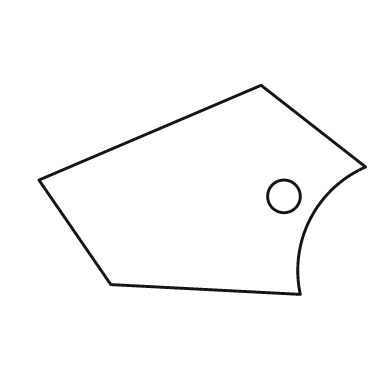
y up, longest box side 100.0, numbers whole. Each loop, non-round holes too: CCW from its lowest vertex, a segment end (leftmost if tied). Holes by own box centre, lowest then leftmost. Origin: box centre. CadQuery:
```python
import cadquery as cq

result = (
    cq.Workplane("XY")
    .moveTo(30.0, -32.0)
    .threePointArc((33.0, -9.0), (50.0, 7.0))
    .lineTo(18.0, 32.0)
    .lineTo(-50.0, 3.0)
    .lineTo(-28.0, -29.0)
    .close()
    .moveTo(25.0, -2.0)
    .circle(5.0)
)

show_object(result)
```